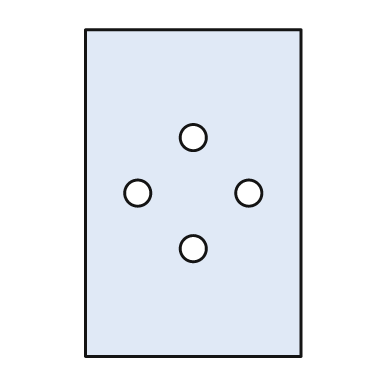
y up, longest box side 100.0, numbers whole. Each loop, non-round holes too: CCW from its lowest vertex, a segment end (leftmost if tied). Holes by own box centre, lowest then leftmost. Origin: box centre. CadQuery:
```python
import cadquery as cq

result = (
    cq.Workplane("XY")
    .moveTo(-33.0, -50.0)
    .lineTo(33.0, -50.0)
    .lineTo(33.0, 50.0)
    .lineTo(-33.0, 50.0)
    .close()
    .moveTo(0.0, -17.0)
    .circle(4.0)
    .moveTo(-17.0, 0.0)
    .circle(4.0)
    .moveTo(17.0, 0.0)
    .circle(4.0)
    .moveTo(0.0, 17.0)
    .circle(4.0)
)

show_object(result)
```